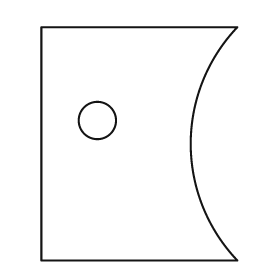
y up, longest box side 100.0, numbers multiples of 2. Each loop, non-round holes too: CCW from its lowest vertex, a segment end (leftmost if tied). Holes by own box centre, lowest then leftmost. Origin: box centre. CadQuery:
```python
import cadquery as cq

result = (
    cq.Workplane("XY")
    .moveTo(-42.0, -50.0)
    .lineTo(42.0, -50.0)
    .threePointArc((22.0, 0.0), (42.0, 50.0))
    .lineTo(-42.0, 50.0)
    .close()
    .moveTo(-18.0, 10.0)
    .circle(8.0)
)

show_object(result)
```